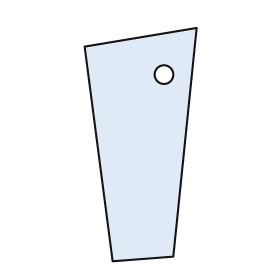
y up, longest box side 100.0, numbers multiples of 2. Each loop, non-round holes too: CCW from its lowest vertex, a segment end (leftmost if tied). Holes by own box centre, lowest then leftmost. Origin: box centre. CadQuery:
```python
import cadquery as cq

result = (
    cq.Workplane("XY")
    .moveTo(-12.0, -50.0)
    .lineTo(14.0, -48.0)
    .lineTo(24.0, 50.0)
    .lineTo(-24.0, 42.0)
    .close()
    .moveTo(10.0, 30.0)
    .circle(4.0)
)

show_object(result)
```